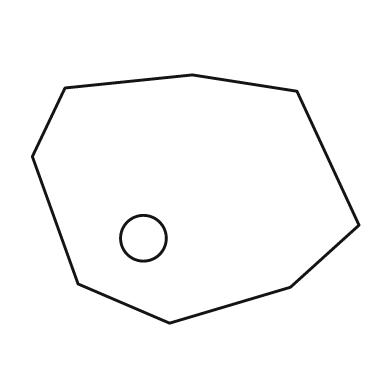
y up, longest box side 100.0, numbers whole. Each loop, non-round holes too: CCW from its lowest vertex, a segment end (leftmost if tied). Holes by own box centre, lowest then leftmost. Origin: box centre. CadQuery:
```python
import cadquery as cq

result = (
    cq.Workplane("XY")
    .moveTo(-8.0, -38.0)
    .lineTo(29.0, -27.0)
    .lineTo(50.0, -8.0)
    .lineTo(31.0, 33.0)
    .lineTo(-1.0, 38.0)
    .lineTo(-40.0, 34.0)
    .lineTo(-50.0, 13.0)
    .lineTo(-36.0, -26.0)
    .close()
    .moveTo(-16.0, -12.0)
    .circle(7.0)
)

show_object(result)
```